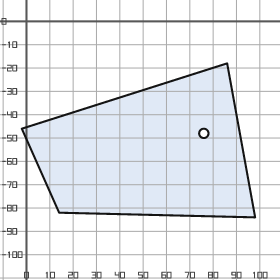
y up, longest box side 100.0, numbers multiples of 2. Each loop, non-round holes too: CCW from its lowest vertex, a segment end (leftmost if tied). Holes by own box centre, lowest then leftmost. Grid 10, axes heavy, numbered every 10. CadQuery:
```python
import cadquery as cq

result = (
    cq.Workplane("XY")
    .moveTo(98.0, -84.0)
    .lineTo(86.0, -18.0)
    .lineTo(-2.0, -46.0)
    .lineTo(14.0, -82.0)
    .close()
    .moveTo(76.0, -48.0)
    .circle(2.0)
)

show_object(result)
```